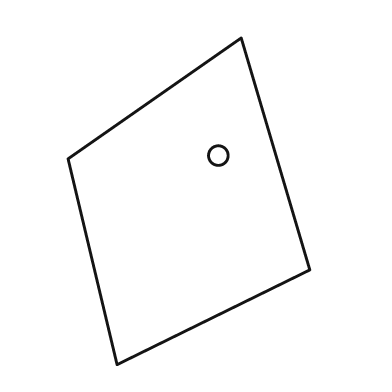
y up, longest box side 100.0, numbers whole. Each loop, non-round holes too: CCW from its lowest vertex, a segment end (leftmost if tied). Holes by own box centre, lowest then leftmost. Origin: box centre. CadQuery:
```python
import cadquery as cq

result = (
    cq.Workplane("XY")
    .moveTo(-22.0, -50.0)
    .lineTo(37.0, -21.0)
    .lineTo(16.0, 50.0)
    .lineTo(-37.0, 13.0)
    .close()
    .moveTo(9.0, 14.0)
    .circle(3.0)
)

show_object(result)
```